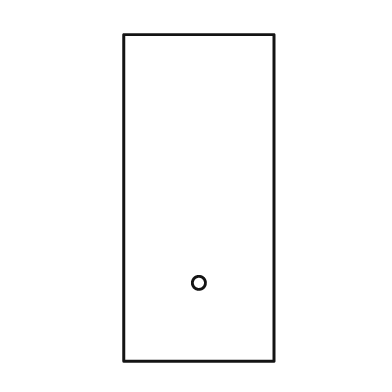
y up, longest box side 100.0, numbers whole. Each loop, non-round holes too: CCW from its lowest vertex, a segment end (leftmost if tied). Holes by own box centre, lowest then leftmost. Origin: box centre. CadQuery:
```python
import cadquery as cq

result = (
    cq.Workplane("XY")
    .moveTo(-23.0, -50.0)
    .lineTo(23.0, -50.0)
    .lineTo(23.0, 50.0)
    .lineTo(-23.0, 50.0)
    .close()
    .moveTo(0.0, -26.0)
    .circle(2.0)
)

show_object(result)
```